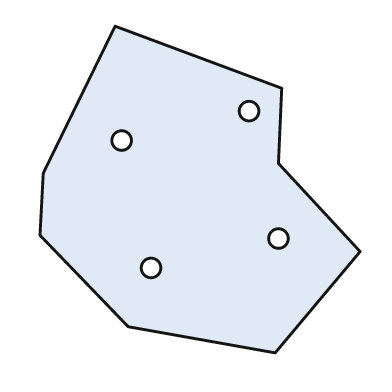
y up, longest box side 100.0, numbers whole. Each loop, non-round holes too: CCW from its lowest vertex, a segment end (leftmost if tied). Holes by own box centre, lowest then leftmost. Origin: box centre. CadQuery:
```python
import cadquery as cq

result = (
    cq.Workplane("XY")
    .moveTo(23.0, -50.0)
    .lineTo(49.0, -19.0)
    .lineTo(24.0, 8.0)
    .lineTo(25.0, 31.0)
    .lineTo(-26.0, 50.0)
    .lineTo(-48.0, 5.0)
    .lineTo(-49.0, -14.0)
    .lineTo(-22.0, -42.0)
    .close()
    .moveTo(-15.0, -24.0)
    .circle(3.0)
    .moveTo(24.0, -15.0)
    .circle(3.0)
    .moveTo(-24.0, 15.0)
    .circle(3.0)
    .moveTo(15.0, 24.0)
    .circle(3.0)
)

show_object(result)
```